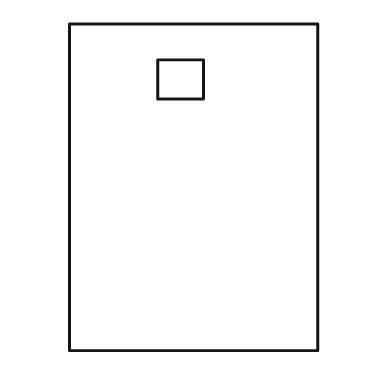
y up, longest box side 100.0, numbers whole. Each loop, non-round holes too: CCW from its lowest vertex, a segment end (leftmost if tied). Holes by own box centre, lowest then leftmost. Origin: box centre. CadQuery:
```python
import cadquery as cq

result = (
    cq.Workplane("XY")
    .moveTo(-38.0, -50.0)
    .lineTo(38.0, -50.0)
    .lineTo(38.0, 50.0)
    .lineTo(-38.0, 50.0)
    .close()
    .moveTo(-11.0, 27.0)
    .lineTo(3.0, 27.0)
    .lineTo(3.0, 39.0)
    .lineTo(-11.0, 39.0)
    .close()
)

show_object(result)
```